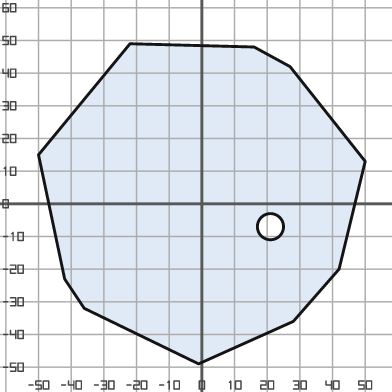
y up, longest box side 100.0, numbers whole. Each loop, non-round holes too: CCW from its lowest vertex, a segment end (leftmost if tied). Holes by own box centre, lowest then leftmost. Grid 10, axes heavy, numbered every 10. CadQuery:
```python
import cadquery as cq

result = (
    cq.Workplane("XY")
    .moveTo(-1.0, -49.0)
    .lineTo(28.0, -36.0)
    .lineTo(42.0, -20.0)
    .lineTo(50.0, 13.0)
    .lineTo(27.0, 42.0)
    .lineTo(16.0, 48.0)
    .lineTo(-22.0, 49.0)
    .lineTo(-50.0, 15.0)
    .lineTo(-42.0, -23.0)
    .lineTo(-36.0, -32.0)
    .close()
    .moveTo(21.0, -7.0)
    .circle(4.0)
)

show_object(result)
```